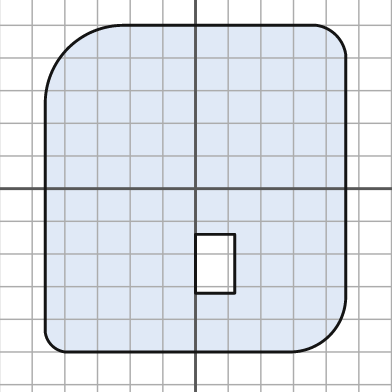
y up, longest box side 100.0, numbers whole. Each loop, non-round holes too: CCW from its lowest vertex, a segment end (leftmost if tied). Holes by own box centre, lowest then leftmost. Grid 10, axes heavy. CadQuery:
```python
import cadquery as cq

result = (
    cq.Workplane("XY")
    .moveTo(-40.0, -50.0)
    .lineTo(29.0, -50.0)
    .threePointArc((41.0, -45.0), (46.0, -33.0))
    .lineTo(46.0, 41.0)
    .threePointArc((43.0, 47.0), (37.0, 50.0))
    .lineTo(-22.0, 50.0)
    .threePointArc((-39.0, 43.0), (-46.0, 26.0))
    .lineTo(-46.0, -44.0)
    .threePointArc((-44.0, -48.0), (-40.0, -50.0))
    .close()
    .moveTo(0.0, -32.0)
    .lineTo(12.0, -32.0)
    .lineTo(12.0, -14.0)
    .lineTo(0.0, -14.0)
    .close()
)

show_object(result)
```